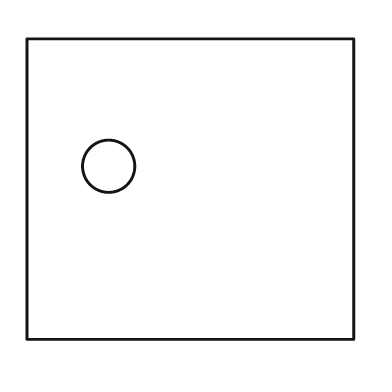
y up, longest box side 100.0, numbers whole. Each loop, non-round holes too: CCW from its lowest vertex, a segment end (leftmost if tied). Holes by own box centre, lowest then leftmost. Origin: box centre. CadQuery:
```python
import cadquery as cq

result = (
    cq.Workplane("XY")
    .moveTo(-50.0, -46.0)
    .lineTo(50.0, -46.0)
    .lineTo(50.0, 46.0)
    .lineTo(-50.0, 46.0)
    .close()
    .moveTo(-25.0, 7.0)
    .circle(8.0)
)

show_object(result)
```